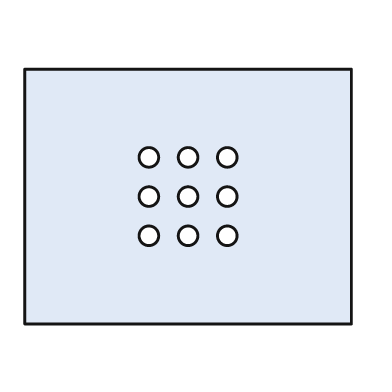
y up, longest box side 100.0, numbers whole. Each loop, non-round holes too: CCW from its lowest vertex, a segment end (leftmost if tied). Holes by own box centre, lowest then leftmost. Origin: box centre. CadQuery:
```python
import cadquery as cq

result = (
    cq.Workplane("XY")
    .moveTo(-50.0, -39.0)
    .lineTo(50.0, -39.0)
    .lineTo(50.0, 39.0)
    .lineTo(-50.0, 39.0)
    .close()
    .moveTo(-12.0, -12.0)
    .circle(3.0)
    .moveTo(0.0, -12.0)
    .circle(3.0)
    .moveTo(12.0, -12.0)
    .circle(3.0)
    .moveTo(-12.0, 0.0)
    .circle(3.0)
    .moveTo(0.0, 0.0)
    .circle(3.0)
    .moveTo(12.0, 0.0)
    .circle(3.0)
    .moveTo(-12.0, 12.0)
    .circle(3.0)
    .moveTo(0.0, 12.0)
    .circle(3.0)
    .moveTo(12.0, 12.0)
    .circle(3.0)
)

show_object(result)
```